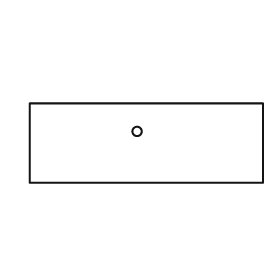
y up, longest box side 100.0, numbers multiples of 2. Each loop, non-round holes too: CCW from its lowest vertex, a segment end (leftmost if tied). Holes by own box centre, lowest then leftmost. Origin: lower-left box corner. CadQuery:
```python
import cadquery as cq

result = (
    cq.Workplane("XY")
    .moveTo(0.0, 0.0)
    .lineTo(100.0, 0.0)
    .lineTo(100.0, 34.0)
    .lineTo(0.0, 34.0)
    .close()
    .moveTo(46.0, 22.0)
    .circle(2.0)
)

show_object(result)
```